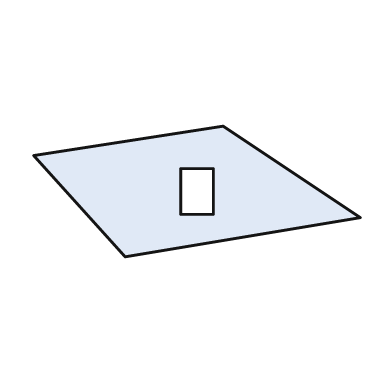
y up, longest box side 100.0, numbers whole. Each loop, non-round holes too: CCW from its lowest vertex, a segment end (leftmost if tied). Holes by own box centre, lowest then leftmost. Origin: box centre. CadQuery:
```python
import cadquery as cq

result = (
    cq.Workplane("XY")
    .moveTo(-22.0, -20.0)
    .lineTo(50.0, -8.0)
    .lineTo(8.0, 20.0)
    .lineTo(-50.0, 11.0)
    .close()
    .moveTo(-5.0, -7.0)
    .lineTo(5.0, -7.0)
    .lineTo(5.0, 7.0)
    .lineTo(-5.0, 7.0)
    .close()
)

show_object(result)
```